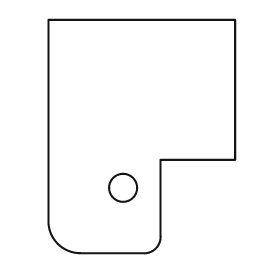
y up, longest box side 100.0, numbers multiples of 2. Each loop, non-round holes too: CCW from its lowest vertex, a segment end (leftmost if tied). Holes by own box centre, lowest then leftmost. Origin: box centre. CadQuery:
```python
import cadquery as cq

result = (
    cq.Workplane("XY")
    .moveTo(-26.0, -50.0)
    .lineTo(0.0, -50.0)
    .threePointArc((6.0, -48.0), (8.0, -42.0))
    .lineTo(8.0, -10.0)
    .lineTo(40.0, -10.0)
    .lineTo(40.0, 50.0)
    .lineTo(-40.0, 50.0)
    .lineTo(-40.0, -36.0)
    .threePointArc((-36.0, -46.0), (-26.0, -50.0))
    .close()
    .moveTo(-8.0, -22.0)
    .circle(6.0)
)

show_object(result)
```